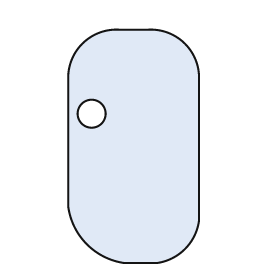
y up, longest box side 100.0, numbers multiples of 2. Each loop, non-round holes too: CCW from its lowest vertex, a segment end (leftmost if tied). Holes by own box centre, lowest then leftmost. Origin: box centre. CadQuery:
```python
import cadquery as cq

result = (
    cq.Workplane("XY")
    .moveTo(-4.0, -50.0)
    .lineTo(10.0, -50.0)
    .threePointArc((22.0, -44.0), (28.0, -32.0))
    .lineTo(28.0, 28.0)
    .threePointArc((22.0, 44.0), (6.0, 50.0))
    .lineTo(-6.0, 50.0)
    .threePointArc((-22.0, 44.0), (-28.0, 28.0))
    .lineTo(-28.0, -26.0)
    .threePointArc((-20.0, -42.0), (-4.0, -50.0))
    .close()
    .moveTo(-18.0, 14.0)
    .circle(6.0)
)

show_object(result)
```